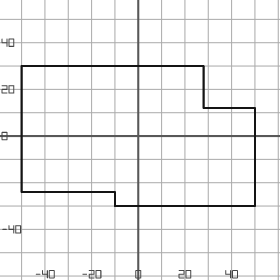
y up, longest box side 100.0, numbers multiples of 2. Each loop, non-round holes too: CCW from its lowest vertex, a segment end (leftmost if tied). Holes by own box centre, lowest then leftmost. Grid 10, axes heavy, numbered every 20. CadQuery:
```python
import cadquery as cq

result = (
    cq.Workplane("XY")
    .moveTo(-10.0, -30.0)
    .lineTo(50.0, -30.0)
    .lineTo(50.0, 12.0)
    .lineTo(28.0, 12.0)
    .lineTo(28.0, 30.0)
    .lineTo(-50.0, 30.0)
    .lineTo(-50.0, -24.0)
    .lineTo(-10.0, -24.0)
    .close()
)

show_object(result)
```